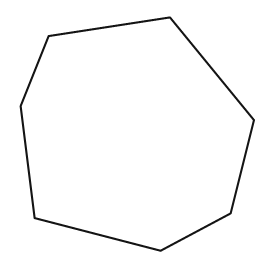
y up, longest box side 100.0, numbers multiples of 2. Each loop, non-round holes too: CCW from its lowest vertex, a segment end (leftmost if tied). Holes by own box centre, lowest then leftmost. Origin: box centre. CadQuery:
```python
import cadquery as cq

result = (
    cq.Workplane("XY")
    .moveTo(10.0, -50.0)
    .lineTo(40.0, -34.0)
    .lineTo(50.0, 6.0)
    .lineTo(14.0, 50.0)
    .lineTo(-38.0, 42.0)
    .lineTo(-50.0, 12.0)
    .lineTo(-44.0, -36.0)
    .close()
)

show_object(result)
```